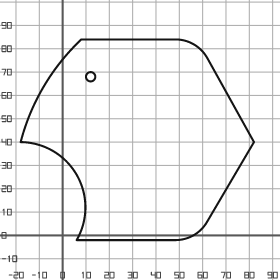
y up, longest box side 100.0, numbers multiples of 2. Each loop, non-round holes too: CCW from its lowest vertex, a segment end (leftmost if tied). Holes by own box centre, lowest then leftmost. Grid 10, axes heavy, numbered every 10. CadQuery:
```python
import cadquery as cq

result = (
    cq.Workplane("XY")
    .moveTo(6.0, -2.0)
    .lineTo(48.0, -2.0)
    .threePointArc((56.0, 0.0), (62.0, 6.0))
    .lineTo(82.0, 40.0)
    .lineTo(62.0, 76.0)
    .threePointArc((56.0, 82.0), (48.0, 84.0))
    .lineTo(8.0, 84.0)
    .threePointArc((-8.0, 64.0), (-18.0, 40.0))
    .threePointArc((6.0, 26.0), (6.0, -2.0))
    .close()
    .moveTo(12.0, 68.0)
    .circle(2.0)
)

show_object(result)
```